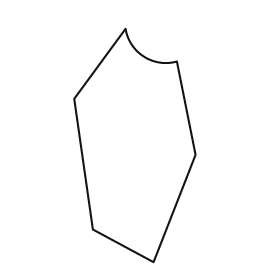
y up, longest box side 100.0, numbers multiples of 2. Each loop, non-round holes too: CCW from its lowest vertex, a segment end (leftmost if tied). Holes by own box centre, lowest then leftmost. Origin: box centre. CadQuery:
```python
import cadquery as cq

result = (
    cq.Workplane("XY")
    .moveTo(8.0, -50.0)
    .lineTo(26.0, -4.0)
    .lineTo(18.0, 36.0)
    .threePointArc((4.0, 38.0), (-4.0, 50.0))
    .lineTo(-26.0, 20.0)
    .lineTo(-18.0, -36.0)
    .close()
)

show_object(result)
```